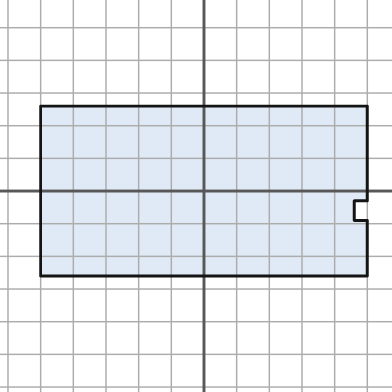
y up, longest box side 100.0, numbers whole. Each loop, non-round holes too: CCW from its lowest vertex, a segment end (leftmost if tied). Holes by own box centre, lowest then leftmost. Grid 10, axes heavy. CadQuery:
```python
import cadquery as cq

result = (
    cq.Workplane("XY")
    .moveTo(-50.0, -26.0)
    .lineTo(50.0, -26.0)
    .lineTo(50.0, -9.0)
    .lineTo(46.0, -9.0)
    .lineTo(46.0, -3.0)
    .lineTo(50.0, -3.0)
    .lineTo(50.0, 26.0)
    .lineTo(-50.0, 26.0)
    .close()
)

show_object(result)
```